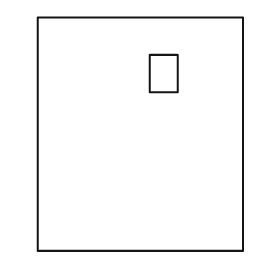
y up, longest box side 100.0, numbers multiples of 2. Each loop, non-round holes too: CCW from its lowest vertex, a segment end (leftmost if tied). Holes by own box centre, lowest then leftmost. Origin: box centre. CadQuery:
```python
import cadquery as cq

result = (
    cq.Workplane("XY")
    .moveTo(-44.0, -50.0)
    .lineTo(44.0, -50.0)
    .lineTo(44.0, 50.0)
    .lineTo(-44.0, 50.0)
    .close()
    .moveTo(4.0, 18.0)
    .lineTo(16.0, 18.0)
    .lineTo(16.0, 34.0)
    .lineTo(4.0, 34.0)
    .close()
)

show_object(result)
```